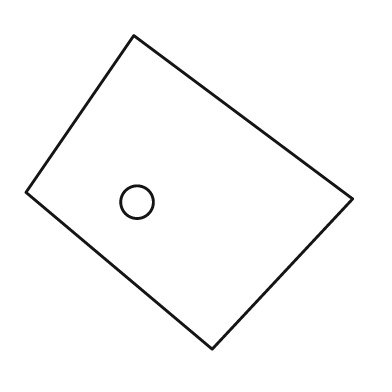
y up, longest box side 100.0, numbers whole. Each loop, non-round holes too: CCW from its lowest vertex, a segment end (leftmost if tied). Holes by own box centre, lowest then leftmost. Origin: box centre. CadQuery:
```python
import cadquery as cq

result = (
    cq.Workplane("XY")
    .moveTo(7.0, -48.0)
    .lineTo(50.0, -2.0)
    .lineTo(-17.0, 48.0)
    .lineTo(-50.0, 0.0)
    .close()
    .moveTo(-16.0, -3.0)
    .circle(5.0)
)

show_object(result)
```